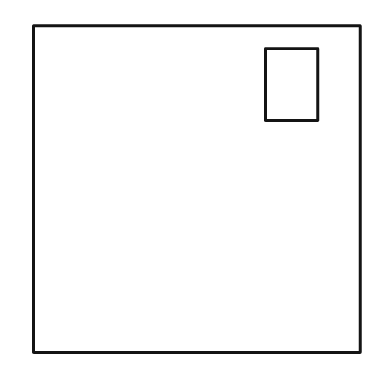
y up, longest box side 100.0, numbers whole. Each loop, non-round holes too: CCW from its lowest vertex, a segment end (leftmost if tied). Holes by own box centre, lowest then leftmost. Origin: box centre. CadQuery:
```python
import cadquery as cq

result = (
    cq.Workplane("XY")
    .moveTo(-50.0, -50.0)
    .lineTo(50.0, -50.0)
    .lineTo(50.0, 50.0)
    .lineTo(-50.0, 50.0)
    .close()
    .moveTo(21.0, 21.0)
    .lineTo(37.0, 21.0)
    .lineTo(37.0, 43.0)
    .lineTo(21.0, 43.0)
    .close()
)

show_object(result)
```